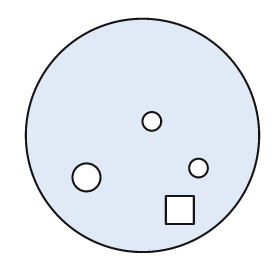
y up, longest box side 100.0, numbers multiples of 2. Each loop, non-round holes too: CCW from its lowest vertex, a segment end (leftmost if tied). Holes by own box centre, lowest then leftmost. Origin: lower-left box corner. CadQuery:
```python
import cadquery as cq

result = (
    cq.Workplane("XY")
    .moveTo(50.0, 50.0)
    .circle(50.0)
    .moveTo(60.0, 12.0)
    .lineTo(72.0, 12.0)
    .lineTo(72.0, 24.0)
    .lineTo(60.0, 24.0)
    .close()
    .moveTo(26.0, 32.0)
    .circle(6.0)
    .moveTo(74.0, 36.0)
    .circle(4.0)
    .moveTo(54.0, 56.0)
    .circle(4.0)
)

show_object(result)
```